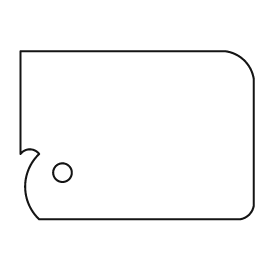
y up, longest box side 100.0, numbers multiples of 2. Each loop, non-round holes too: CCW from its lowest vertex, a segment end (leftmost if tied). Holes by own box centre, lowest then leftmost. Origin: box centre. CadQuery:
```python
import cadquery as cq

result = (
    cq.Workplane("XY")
    .moveTo(-42.0, -36.0)
    .lineTo(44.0, -36.0)
    .threePointArc((48.0, -34.0), (50.0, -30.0))
    .lineTo(50.0, 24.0)
    .threePointArc((46.0, 32.0), (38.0, 36.0))
    .lineTo(-50.0, 36.0)
    .lineTo(-50.0, -8.0)
    .threePointArc((-46.0, -6.0), (-42.0, -8.0))
    .threePointArc((-48.0, -22.0), (-42.0, -36.0))
    .close()
    .moveTo(-32.0, -16.0)
    .circle(4.0)
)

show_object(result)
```